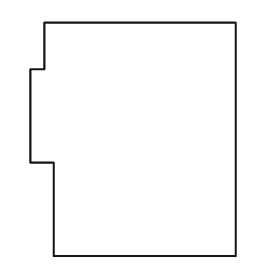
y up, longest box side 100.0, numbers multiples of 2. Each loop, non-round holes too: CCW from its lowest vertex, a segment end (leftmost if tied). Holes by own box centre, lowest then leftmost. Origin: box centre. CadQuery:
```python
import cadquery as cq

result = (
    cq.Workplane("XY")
    .moveTo(-34.0, -50.0)
    .lineTo(44.0, -50.0)
    .lineTo(44.0, 50.0)
    .lineTo(-38.0, 50.0)
    .lineTo(-38.0, 30.0)
    .lineTo(-44.0, 30.0)
    .lineTo(-44.0, -10.0)
    .lineTo(-34.0, -10.0)
    .close()
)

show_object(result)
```